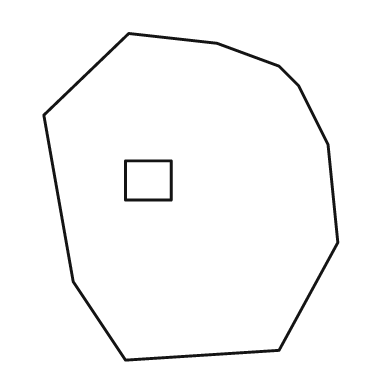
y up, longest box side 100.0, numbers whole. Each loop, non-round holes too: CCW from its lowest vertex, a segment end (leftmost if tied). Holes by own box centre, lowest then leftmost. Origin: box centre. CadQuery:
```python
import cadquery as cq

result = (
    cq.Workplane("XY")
    .moveTo(-20.0, -50.0)
    .lineTo(27.0, -47.0)
    .lineTo(45.0, -14.0)
    .lineTo(42.0, 16.0)
    .lineTo(33.0, 34.0)
    .lineTo(27.0, 40.0)
    .lineTo(8.0, 47.0)
    .lineTo(-19.0, 50.0)
    .lineTo(-45.0, 25.0)
    .lineTo(-36.0, -26.0)
    .close()
    .moveTo(-20.0, -1.0)
    .lineTo(-6.0, -1.0)
    .lineTo(-6.0, 11.0)
    .lineTo(-20.0, 11.0)
    .close()
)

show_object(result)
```